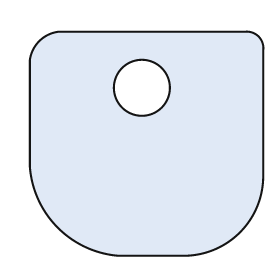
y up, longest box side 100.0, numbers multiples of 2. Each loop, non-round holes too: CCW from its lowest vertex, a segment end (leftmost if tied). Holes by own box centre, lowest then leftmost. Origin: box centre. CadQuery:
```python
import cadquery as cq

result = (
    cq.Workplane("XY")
    .moveTo(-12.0, -48.0)
    .lineTo(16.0, -48.0)
    .threePointArc((40.0, -38.0), (50.0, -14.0))
    .lineTo(50.0, 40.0)
    .threePointArc((48.0, 46.0), (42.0, 48.0))
    .lineTo(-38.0, 48.0)
    .threePointArc((-46.0, 44.0), (-50.0, 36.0))
    .lineTo(-50.0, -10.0)
    .threePointArc((-38.0, -36.0), (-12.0, -48.0))
    .close()
    .moveTo(-2.0, 24.0)
    .circle(12.0)
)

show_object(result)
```